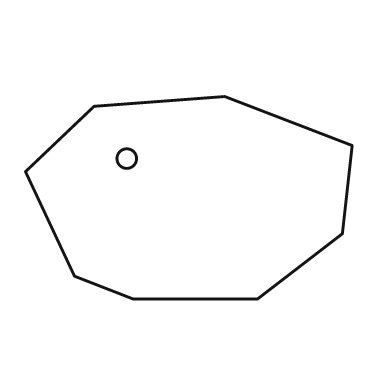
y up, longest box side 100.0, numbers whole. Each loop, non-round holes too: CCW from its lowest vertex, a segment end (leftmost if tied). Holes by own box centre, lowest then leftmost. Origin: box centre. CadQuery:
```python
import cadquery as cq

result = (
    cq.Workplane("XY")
    .moveTo(-17.0, -31.0)
    .lineTo(21.0, -31.0)
    .lineTo(47.0, -11.0)
    .lineTo(50.0, 16.0)
    .lineTo(11.0, 31.0)
    .lineTo(-29.0, 28.0)
    .lineTo(-50.0, 8.0)
    .lineTo(-35.0, -24.0)
    .close()
    .moveTo(-19.0, 12.0)
    .circle(3.0)
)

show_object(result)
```